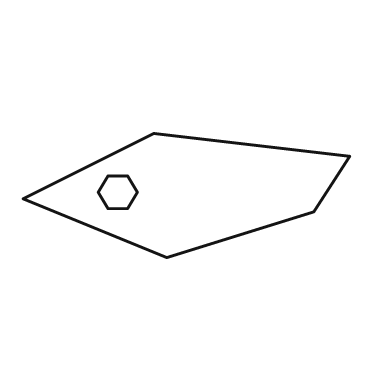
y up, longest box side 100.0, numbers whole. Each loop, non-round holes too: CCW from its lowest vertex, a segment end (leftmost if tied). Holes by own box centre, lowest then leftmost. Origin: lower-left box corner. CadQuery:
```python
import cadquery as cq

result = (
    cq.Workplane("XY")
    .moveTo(44.0, 0.0)
    .lineTo(89.0, 14.0)
    .lineTo(100.0, 31.0)
    .lineTo(40.0, 38.0)
    .lineTo(0.0, 18.0)
    .close()
    .moveTo(26.0, 15.0)
    .lineTo(32.0, 15.0)
    .lineTo(35.0, 20.0)
    .lineTo(32.0, 25.0)
    .lineTo(26.0, 25.0)
    .lineTo(23.0, 20.0)
    .close()
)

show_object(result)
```